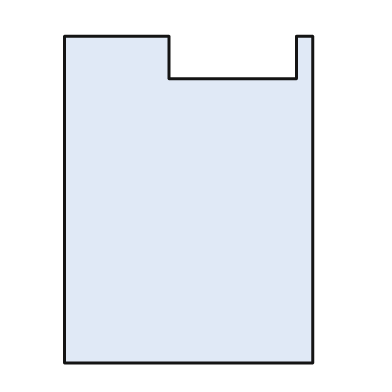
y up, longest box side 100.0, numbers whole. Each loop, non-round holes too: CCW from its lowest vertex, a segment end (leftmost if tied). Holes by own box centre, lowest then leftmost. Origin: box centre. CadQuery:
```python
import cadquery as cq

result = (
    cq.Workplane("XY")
    .moveTo(-38.0, -50.0)
    .lineTo(38.0, -50.0)
    .lineTo(38.0, 50.0)
    .lineTo(33.0, 50.0)
    .lineTo(33.0, 37.0)
    .lineTo(-6.0, 37.0)
    .lineTo(-6.0, 50.0)
    .lineTo(-38.0, 50.0)
    .close()
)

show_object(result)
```